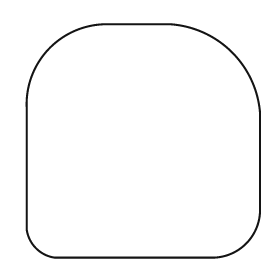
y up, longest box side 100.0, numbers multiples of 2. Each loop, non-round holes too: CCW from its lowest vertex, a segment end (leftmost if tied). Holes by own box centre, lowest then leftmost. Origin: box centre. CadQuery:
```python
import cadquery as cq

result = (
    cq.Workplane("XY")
    .moveTo(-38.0, -50.0)
    .lineTo(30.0, -50.0)
    .threePointArc((44.0, -44.0), (50.0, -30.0))
    .lineTo(50.0, 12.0)
    .threePointArc((38.0, 38.0), (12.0, 50.0))
    .lineTo(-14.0, 50.0)
    .threePointArc((-40.0, 40.0), (-50.0, 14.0))
    .lineTo(-50.0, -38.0)
    .threePointArc((-46.0, -46.0), (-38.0, -50.0))
    .close()
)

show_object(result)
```